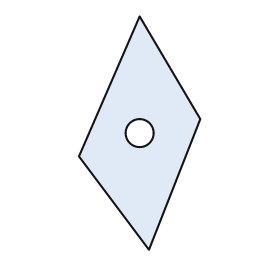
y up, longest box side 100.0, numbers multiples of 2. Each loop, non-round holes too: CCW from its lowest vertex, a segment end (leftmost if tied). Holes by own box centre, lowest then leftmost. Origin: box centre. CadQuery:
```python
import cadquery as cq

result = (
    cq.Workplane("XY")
    .moveTo(4.0, -50.0)
    .lineTo(26.0, 6.0)
    .lineTo(0.0, 50.0)
    .lineTo(-26.0, -10.0)
    .close()
    .moveTo(0.0, 0.0)
    .circle(6.0)
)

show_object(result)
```